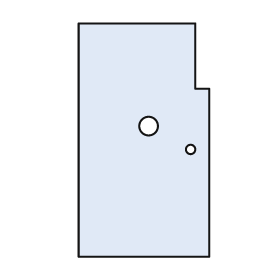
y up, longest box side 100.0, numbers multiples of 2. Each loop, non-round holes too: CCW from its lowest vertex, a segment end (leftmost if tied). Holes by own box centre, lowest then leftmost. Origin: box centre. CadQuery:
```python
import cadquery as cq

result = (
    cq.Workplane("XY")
    .moveTo(-28.0, -50.0)
    .lineTo(28.0, -50.0)
    .lineTo(28.0, 22.0)
    .lineTo(22.0, 22.0)
    .lineTo(22.0, 50.0)
    .lineTo(-28.0, 50.0)
    .close()
    .moveTo(20.0, -4.0)
    .circle(2.0)
    .moveTo(2.0, 6.0)
    .circle(4.0)
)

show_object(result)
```